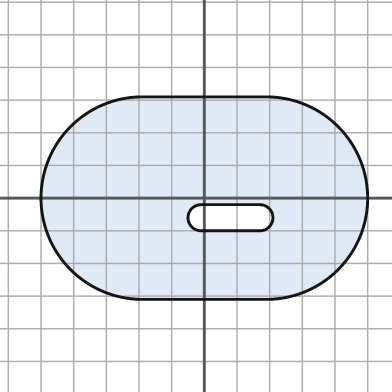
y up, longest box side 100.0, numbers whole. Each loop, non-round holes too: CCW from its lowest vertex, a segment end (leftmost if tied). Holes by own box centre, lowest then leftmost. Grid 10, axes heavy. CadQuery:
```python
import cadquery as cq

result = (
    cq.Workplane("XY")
    .moveTo(-19.0, -31.0)
    .lineTo(19.0, -31.0)
    .threePointArc((50.0, 0.0), (19.0, 31.0))
    .lineTo(-19.0, 31.0)
    .threePointArc((-50.0, 0.0), (-19.0, -31.0))
    .close()
    .moveTo(-1.0, -10.0)
    .lineTo(17.0, -10.0)
    .threePointArc((21.0, -6.0), (17.0, -2.0))
    .lineTo(-1.0, -2.0)
    .threePointArc((-5.0, -6.0), (-1.0, -10.0))
    .close()
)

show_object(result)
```